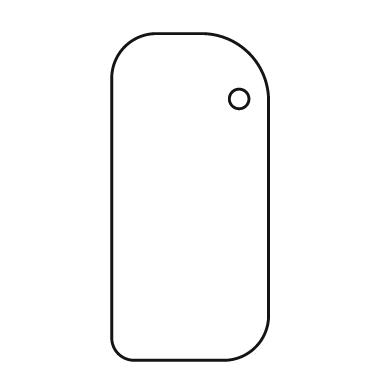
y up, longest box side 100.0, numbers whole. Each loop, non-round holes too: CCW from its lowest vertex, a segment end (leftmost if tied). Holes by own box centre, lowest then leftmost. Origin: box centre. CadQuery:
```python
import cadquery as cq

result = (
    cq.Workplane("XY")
    .moveTo(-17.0, -50.0)
    .lineTo(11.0, -50.0)
    .threePointArc((20.0, -46.0), (24.0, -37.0))
    .lineTo(24.0, 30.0)
    .threePointArc((18.0, 44.0), (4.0, 50.0))
    .lineTo(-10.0, 50.0)
    .threePointArc((-20.0, 46.0), (-24.0, 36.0))
    .lineTo(-24.0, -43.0)
    .threePointArc((-22.0, -48.0), (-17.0, -50.0))
    .close()
    .moveTo(15.0, 30.0)
    .circle(3.0)
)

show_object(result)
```